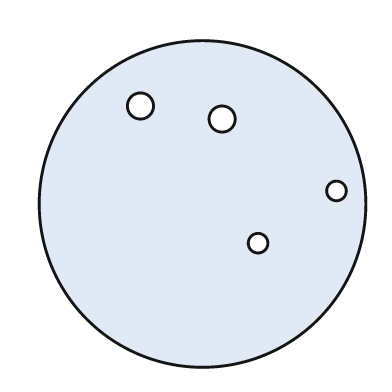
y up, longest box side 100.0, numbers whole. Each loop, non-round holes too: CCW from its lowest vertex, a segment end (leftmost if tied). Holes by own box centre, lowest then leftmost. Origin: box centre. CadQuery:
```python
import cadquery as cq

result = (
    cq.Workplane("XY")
    .moveTo(0.0, 0.0)
    .circle(50.0)
    .moveTo(17.0, -12.0)
    .circle(3.0)
    .moveTo(41.0, 4.0)
    .circle(3.0)
    .moveTo(6.0, 26.0)
    .circle(4.0)
    .moveTo(-19.0, 30.0)
    .circle(4.0)
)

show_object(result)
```